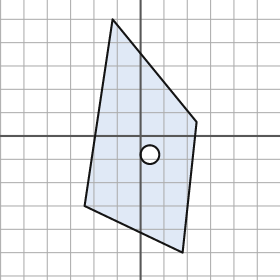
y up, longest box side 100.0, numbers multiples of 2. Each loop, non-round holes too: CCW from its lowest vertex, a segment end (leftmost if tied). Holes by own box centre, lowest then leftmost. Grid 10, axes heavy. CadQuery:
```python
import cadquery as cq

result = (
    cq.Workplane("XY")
    .moveTo(18.0, -50.0)
    .lineTo(24.0, 6.0)
    .lineTo(-12.0, 50.0)
    .lineTo(-24.0, -30.0)
    .close()
    .moveTo(4.0, -8.0)
    .circle(4.0)
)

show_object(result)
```